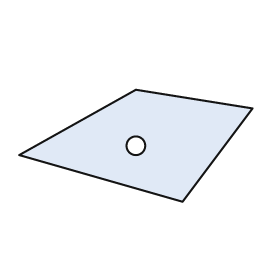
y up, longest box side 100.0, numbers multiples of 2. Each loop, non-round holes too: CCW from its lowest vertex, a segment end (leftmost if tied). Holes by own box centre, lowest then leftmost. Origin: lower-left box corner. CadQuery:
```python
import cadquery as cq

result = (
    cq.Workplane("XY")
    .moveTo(70.0, 0.0)
    .lineTo(100.0, 40.0)
    .lineTo(50.0, 48.0)
    .lineTo(0.0, 20.0)
    .close()
    .moveTo(50.0, 24.0)
    .circle(4.0)
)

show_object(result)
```